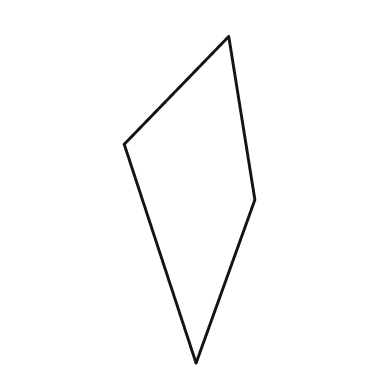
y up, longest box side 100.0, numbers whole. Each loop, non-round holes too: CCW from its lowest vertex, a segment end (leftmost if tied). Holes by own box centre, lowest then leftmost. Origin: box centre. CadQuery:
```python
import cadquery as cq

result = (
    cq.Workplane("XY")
    .moveTo(2.0, -50.0)
    .lineTo(20.0, 0.0)
    .lineTo(12.0, 50.0)
    .lineTo(-20.0, 17.0)
    .close()
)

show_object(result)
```